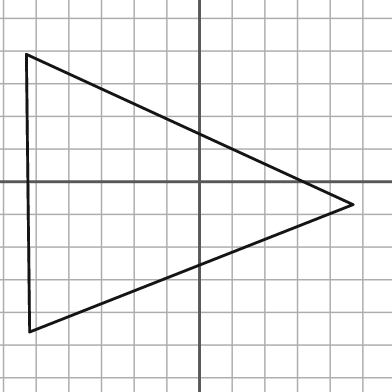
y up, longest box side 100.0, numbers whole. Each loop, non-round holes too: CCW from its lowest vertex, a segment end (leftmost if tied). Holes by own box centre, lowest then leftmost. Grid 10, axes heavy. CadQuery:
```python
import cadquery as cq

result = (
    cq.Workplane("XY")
    .moveTo(-52.0, -46.0)
    .lineTo(47.0, -7.0)
    .lineTo(-53.0, 39.0)
    .close()
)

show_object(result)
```